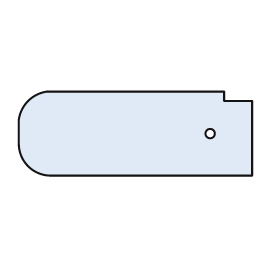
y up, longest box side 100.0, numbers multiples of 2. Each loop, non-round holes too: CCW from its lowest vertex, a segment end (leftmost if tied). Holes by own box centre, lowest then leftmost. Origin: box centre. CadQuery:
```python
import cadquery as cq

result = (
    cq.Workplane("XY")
    .moveTo(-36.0, -18.0)
    .lineTo(50.0, -18.0)
    .lineTo(50.0, 14.0)
    .lineTo(38.0, 14.0)
    .lineTo(38.0, 18.0)
    .lineTo(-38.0, 18.0)
    .threePointArc((-46.0, 14.0), (-50.0, 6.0))
    .lineTo(-50.0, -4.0)
    .threePointArc((-46.0, -14.0), (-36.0, -18.0))
    .close()
    .moveTo(32.0, 0.0)
    .circle(2.0)
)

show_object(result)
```